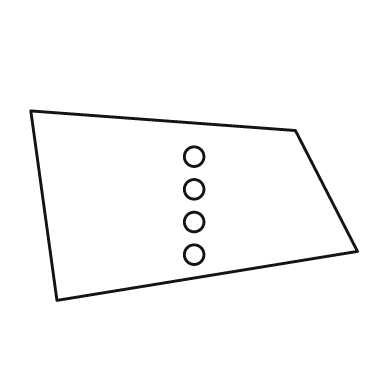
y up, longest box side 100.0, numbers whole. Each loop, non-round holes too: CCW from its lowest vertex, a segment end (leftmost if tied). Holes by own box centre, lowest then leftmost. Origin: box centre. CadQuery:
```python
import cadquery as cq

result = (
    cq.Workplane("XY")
    .moveTo(-42.0, -29.0)
    .lineTo(50.0, -14.0)
    .lineTo(31.0, 23.0)
    .lineTo(-50.0, 29.0)
    .close()
    .moveTo(0.0, -15.0)
    .circle(3.0)
    .moveTo(0.0, -5.0)
    .circle(3.0)
    .moveTo(0.0, 5.0)
    .circle(3.0)
    .moveTo(0.0, 15.0)
    .circle(3.0)
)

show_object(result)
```